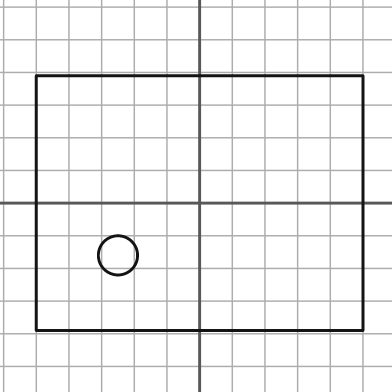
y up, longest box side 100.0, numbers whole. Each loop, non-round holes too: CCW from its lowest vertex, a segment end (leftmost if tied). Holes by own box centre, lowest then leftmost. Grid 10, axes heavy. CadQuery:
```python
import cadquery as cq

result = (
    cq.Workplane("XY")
    .moveTo(-50.0, -39.0)
    .lineTo(50.0, -39.0)
    .lineTo(50.0, 39.0)
    .lineTo(-50.0, 39.0)
    .close()
    .moveTo(-25.0, -16.0)
    .circle(6.0)
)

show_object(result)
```